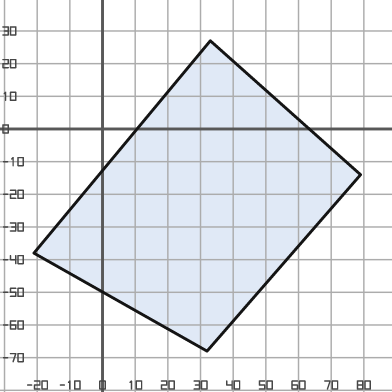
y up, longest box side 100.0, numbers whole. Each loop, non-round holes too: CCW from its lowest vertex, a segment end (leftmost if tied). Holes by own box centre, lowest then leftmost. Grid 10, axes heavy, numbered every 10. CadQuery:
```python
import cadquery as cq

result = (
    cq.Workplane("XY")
    .moveTo(32.0, -68.0)
    .lineTo(79.0, -14.0)
    .lineTo(33.0, 27.0)
    .lineTo(-21.0, -38.0)
    .close()
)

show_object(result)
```